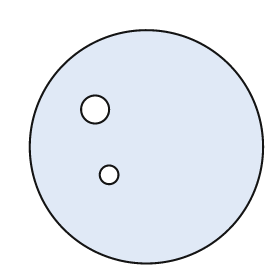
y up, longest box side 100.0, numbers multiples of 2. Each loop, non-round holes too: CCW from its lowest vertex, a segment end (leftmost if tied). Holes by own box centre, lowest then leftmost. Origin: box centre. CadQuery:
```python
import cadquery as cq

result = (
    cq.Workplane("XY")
    .moveTo(0.0, 0.0)
    .circle(50.0)
    .moveTo(-16.0, -12.0)
    .circle(4.0)
    .moveTo(-22.0, 16.0)
    .circle(6.0)
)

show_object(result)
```